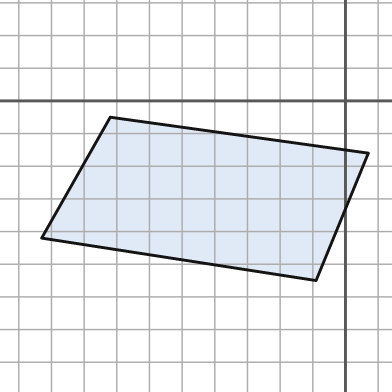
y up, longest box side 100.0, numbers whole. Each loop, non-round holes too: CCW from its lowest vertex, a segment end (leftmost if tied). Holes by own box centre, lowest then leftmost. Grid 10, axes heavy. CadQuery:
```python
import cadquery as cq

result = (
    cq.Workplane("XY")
    .moveTo(-9.0, -55.0)
    .lineTo(7.0, -16.0)
    .lineTo(-72.0, -5.0)
    .lineTo(-93.0, -42.0)
    .close()
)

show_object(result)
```